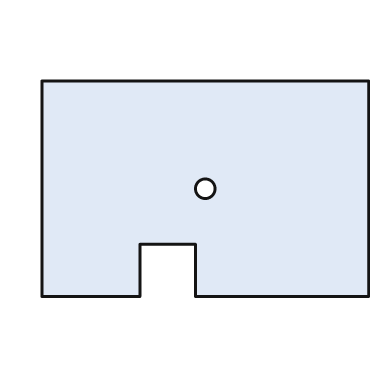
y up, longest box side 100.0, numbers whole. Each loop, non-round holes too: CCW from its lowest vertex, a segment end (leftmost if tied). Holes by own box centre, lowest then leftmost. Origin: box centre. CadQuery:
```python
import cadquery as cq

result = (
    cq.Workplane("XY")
    .moveTo(-50.0, -33.0)
    .lineTo(-20.0, -33.0)
    .lineTo(-20.0, -17.0)
    .lineTo(-3.0, -17.0)
    .lineTo(-3.0, -33.0)
    .lineTo(50.0, -33.0)
    .lineTo(50.0, 33.0)
    .lineTo(-50.0, 33.0)
    .close()
    .moveTo(0.0, 0.0)
    .circle(3.0)
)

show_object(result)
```